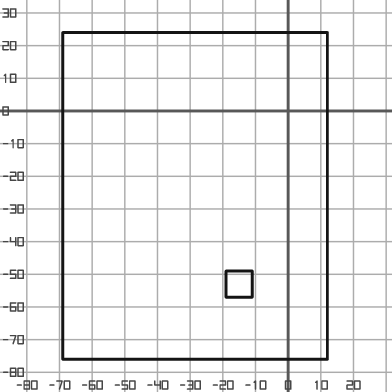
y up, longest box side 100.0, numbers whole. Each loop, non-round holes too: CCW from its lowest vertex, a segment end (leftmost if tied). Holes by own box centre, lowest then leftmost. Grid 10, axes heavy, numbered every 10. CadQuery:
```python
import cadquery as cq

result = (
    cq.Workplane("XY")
    .moveTo(-69.0, -76.0)
    .lineTo(12.0, -76.0)
    .lineTo(12.0, 24.0)
    .lineTo(-69.0, 24.0)
    .close()
    .moveTo(-19.0, -57.0)
    .lineTo(-11.0, -57.0)
    .lineTo(-11.0, -49.0)
    .lineTo(-19.0, -49.0)
    .close()
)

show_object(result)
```